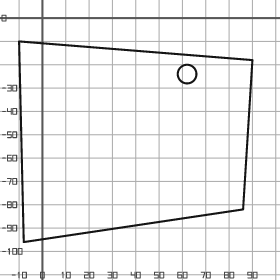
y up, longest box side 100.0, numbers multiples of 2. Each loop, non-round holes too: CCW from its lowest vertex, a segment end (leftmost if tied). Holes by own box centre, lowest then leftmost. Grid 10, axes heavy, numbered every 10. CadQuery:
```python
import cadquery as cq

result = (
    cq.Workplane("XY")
    .moveTo(-8.0, -96.0)
    .lineTo(86.0, -82.0)
    .lineTo(90.0, -18.0)
    .lineTo(-10.0, -10.0)
    .close()
    .moveTo(62.0, -24.0)
    .circle(4.0)
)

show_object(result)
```